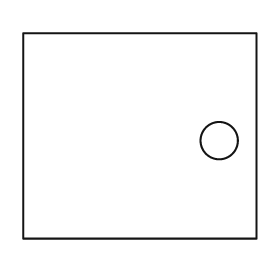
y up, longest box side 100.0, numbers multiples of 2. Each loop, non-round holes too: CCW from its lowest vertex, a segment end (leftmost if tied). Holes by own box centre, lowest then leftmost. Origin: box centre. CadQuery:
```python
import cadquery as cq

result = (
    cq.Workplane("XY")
    .moveTo(-50.0, -44.0)
    .lineTo(50.0, -44.0)
    .lineTo(50.0, 44.0)
    .lineTo(-50.0, 44.0)
    .close()
    .moveTo(34.0, -2.0)
    .circle(8.0)
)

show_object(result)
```